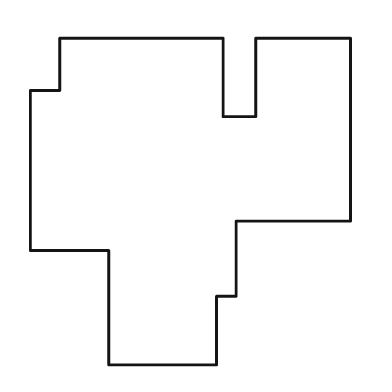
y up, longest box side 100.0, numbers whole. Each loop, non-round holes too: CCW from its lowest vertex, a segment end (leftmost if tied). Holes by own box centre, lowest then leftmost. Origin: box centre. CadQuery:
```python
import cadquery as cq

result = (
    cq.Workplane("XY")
    .moveTo(-25.0, -50.0)
    .lineTo(8.0, -50.0)
    .lineTo(8.0, -29.0)
    .lineTo(14.0, -29.0)
    .lineTo(14.0, -6.0)
    .lineTo(49.0, -6.0)
    .lineTo(49.0, 50.0)
    .lineTo(20.0, 50.0)
    .lineTo(20.0, 26.0)
    .lineTo(10.0, 26.0)
    .lineTo(10.0, 50.0)
    .lineTo(-40.0, 50.0)
    .lineTo(-40.0, 34.0)
    .lineTo(-49.0, 34.0)
    .lineTo(-49.0, -15.0)
    .lineTo(-25.0, -15.0)
    .close()
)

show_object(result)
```